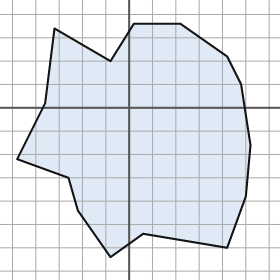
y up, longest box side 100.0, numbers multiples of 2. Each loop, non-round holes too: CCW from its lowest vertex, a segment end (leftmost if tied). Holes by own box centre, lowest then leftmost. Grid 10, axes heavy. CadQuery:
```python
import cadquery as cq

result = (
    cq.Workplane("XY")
    .moveTo(-8.0, -64.0)
    .lineTo(6.0, -54.0)
    .lineTo(42.0, -60.0)
    .lineTo(50.0, -38.0)
    .lineTo(52.0, -16.0)
    .lineTo(48.0, 10.0)
    .lineTo(42.0, 22.0)
    .lineTo(22.0, 36.0)
    .lineTo(2.0, 36.0)
    .lineTo(-8.0, 20.0)
    .lineTo(-32.0, 34.0)
    .lineTo(-36.0, 2.0)
    .lineTo(-48.0, -22.0)
    .lineTo(-26.0, -30.0)
    .lineTo(-22.0, -44.0)
    .close()
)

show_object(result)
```